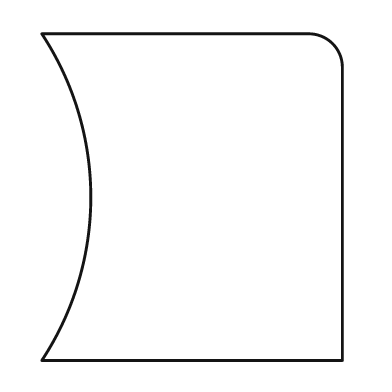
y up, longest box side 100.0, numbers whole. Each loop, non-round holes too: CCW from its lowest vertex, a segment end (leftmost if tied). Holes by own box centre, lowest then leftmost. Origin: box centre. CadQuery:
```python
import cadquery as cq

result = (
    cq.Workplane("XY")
    .moveTo(-46.0, -50.0)
    .lineTo(46.0, -50.0)
    .lineTo(46.0, 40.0)
    .threePointArc((43.0, 47.0), (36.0, 50.0))
    .lineTo(-46.0, 50.0)
    .threePointArc((-31.0, 0.0), (-46.0, -50.0))
    .close()
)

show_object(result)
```